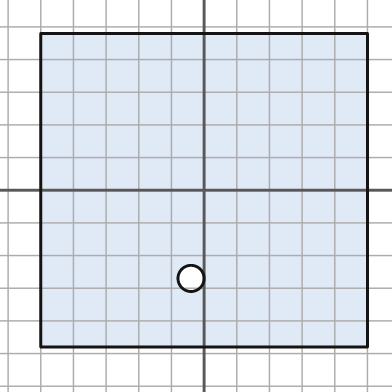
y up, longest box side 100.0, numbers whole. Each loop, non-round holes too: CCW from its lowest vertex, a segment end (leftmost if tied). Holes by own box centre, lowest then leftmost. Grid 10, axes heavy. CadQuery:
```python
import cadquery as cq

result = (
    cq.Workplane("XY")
    .moveTo(-50.0, -48.0)
    .lineTo(50.0, -48.0)
    .lineTo(50.0, 48.0)
    .lineTo(-50.0, 48.0)
    .close()
    .moveTo(-4.0, -27.0)
    .circle(4.0)
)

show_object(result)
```